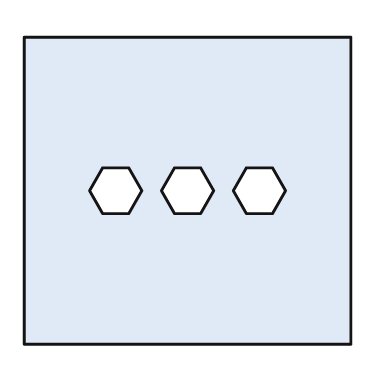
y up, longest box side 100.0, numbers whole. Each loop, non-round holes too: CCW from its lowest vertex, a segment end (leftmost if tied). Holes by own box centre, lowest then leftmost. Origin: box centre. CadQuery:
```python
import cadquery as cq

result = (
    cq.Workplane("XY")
    .moveTo(-50.0, -47.0)
    .lineTo(50.0, -47.0)
    .lineTo(50.0, 47.0)
    .lineTo(-50.0, 47.0)
    .close()
    .moveTo(-26.0, -7.0)
    .lineTo(-18.0, -7.0)
    .lineTo(-14.0, 0.0)
    .lineTo(-18.0, 7.0)
    .lineTo(-26.0, 7.0)
    .lineTo(-30.0, 0.0)
    .close()
    .moveTo(-4.0, -7.0)
    .lineTo(4.0, -7.0)
    .lineTo(8.0, 0.0)
    .lineTo(4.0, 7.0)
    .lineTo(-4.0, 7.0)
    .lineTo(-8.0, 0.0)
    .close()
    .moveTo(18.0, -7.0)
    .lineTo(26.0, -7.0)
    .lineTo(30.0, 0.0)
    .lineTo(26.0, 7.0)
    .lineTo(18.0, 7.0)
    .lineTo(14.0, 0.0)
    .close()
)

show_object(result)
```